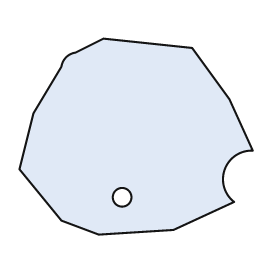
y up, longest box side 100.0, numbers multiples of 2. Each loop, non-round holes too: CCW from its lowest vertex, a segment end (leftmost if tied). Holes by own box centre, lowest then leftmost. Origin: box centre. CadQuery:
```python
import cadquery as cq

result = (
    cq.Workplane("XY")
    .moveTo(-16.0, -42.0)
    .lineTo(16.0, -40.0)
    .lineTo(42.0, -28.0)
    .threePointArc((38.0, -14.0), (50.0, -6.0))
    .lineTo(40.0, 16.0)
    .lineTo(24.0, 38.0)
    .lineTo(-14.0, 42.0)
    .lineTo(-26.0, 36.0)
    .threePointArc((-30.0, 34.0), (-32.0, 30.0))
    .lineTo(-44.0, 10.0)
    .lineTo(-50.0, -14.0)
    .lineTo(-32.0, -36.0)
    .close()
    .moveTo(-6.0, -26.0)
    .circle(4.0)
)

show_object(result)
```